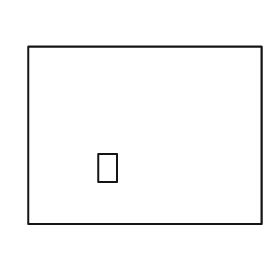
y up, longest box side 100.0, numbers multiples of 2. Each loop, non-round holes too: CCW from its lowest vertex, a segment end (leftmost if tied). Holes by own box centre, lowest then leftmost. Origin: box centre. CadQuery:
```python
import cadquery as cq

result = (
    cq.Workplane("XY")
    .moveTo(-50.0, -38.0)
    .lineTo(50.0, -38.0)
    .lineTo(50.0, 38.0)
    .lineTo(-50.0, 38.0)
    .close()
    .moveTo(-20.0, -20.0)
    .lineTo(-12.0, -20.0)
    .lineTo(-12.0, -8.0)
    .lineTo(-20.0, -8.0)
    .close()
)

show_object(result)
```